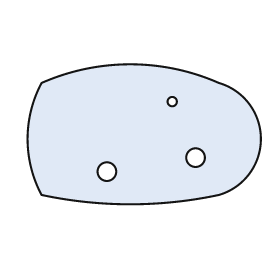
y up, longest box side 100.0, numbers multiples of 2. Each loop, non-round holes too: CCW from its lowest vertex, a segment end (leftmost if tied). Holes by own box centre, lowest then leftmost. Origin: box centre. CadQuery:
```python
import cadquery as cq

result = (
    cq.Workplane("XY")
    .moveTo(-44.0, -26.0)
    .threePointArc((-6.0, -30.0), (32.0, -26.0))
    .threePointArc((50.0, -2.0), (32.0, 22.0))
    .threePointArc((-6.0, 30.0), (-44.0, 22.0))
    .threePointArc((-50.0, -2.0), (-44.0, -26.0))
    .close()
    .moveTo(-16.0, -16.0)
    .circle(4.0)
    .moveTo(22.0, -10.0)
    .circle(4.0)
    .moveTo(12.0, 14.0)
    .circle(2.0)
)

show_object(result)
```